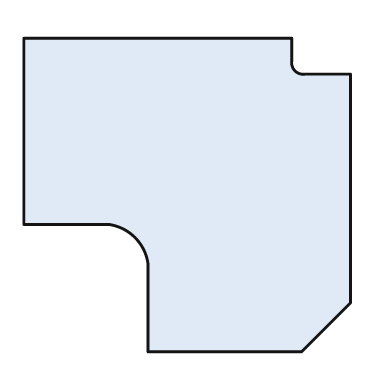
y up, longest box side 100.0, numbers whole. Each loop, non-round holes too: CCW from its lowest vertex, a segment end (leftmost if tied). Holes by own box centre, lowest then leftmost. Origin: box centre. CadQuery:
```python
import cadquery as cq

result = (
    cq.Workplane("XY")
    .moveTo(-12.0, -48.0)
    .lineTo(35.0, -48.0)
    .lineTo(50.0, -33.0)
    .lineTo(50.0, 37.0)
    .lineTo(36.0, 37.0)
    .threePointArc((33.0, 38.0), (32.0, 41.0))
    .lineTo(32.0, 48.0)
    .lineTo(-50.0, 48.0)
    .lineTo(-50.0, -9.0)
    .lineTo(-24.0, -9.0)
    .threePointArc((-16.0, -13.0), (-12.0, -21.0))
    .close()
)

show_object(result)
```